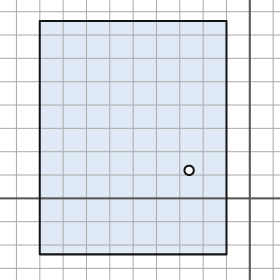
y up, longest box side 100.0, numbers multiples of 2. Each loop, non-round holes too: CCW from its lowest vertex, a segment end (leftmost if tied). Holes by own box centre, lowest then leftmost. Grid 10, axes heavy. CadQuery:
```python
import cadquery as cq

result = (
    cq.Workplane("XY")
    .moveTo(-90.0, -24.0)
    .lineTo(-10.0, -24.0)
    .lineTo(-10.0, 76.0)
    .lineTo(-90.0, 76.0)
    .close()
    .moveTo(-26.0, 12.0)
    .circle(2.0)
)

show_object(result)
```